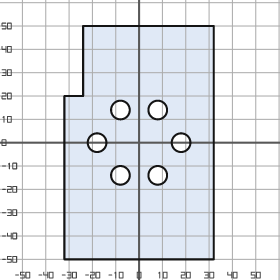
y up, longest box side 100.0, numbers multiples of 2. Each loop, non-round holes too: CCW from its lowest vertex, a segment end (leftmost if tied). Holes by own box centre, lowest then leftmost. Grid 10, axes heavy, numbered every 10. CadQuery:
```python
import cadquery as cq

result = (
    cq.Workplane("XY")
    .moveTo(-32.0, -50.0)
    .lineTo(32.0, -50.0)
    .lineTo(32.0, 50.0)
    .lineTo(-24.0, 50.0)
    .lineTo(-24.0, 20.0)
    .lineTo(-32.0, 20.0)
    .close()
    .moveTo(-8.0, -14.0)
    .circle(4.0)
    .moveTo(8.0, -14.0)
    .circle(4.0)
    .moveTo(-18.0, 0.0)
    .circle(4.0)
    .moveTo(18.0, 0.0)
    .circle(4.0)
    .moveTo(-8.0, 14.0)
    .circle(4.0)
    .moveTo(8.0, 14.0)
    .circle(4.0)
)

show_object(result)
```